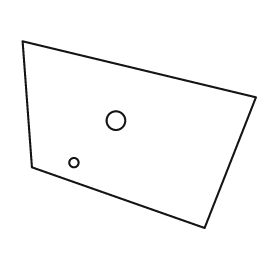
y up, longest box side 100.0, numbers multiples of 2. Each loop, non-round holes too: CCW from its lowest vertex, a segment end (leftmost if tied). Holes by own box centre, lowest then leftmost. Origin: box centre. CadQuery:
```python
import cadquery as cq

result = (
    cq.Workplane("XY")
    .moveTo(28.0, -40.0)
    .lineTo(50.0, 16.0)
    .lineTo(-50.0, 40.0)
    .lineTo(-46.0, -14.0)
    .close()
    .moveTo(-28.0, -12.0)
    .circle(2.0)
    .moveTo(-10.0, 6.0)
    .circle(4.0)
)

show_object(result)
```